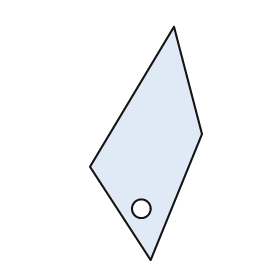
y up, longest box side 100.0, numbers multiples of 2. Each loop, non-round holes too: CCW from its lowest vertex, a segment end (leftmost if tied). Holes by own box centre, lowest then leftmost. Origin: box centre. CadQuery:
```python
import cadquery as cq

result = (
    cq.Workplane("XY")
    .moveTo(2.0, -50.0)
    .lineTo(24.0, 4.0)
    .lineTo(12.0, 50.0)
    .lineTo(-24.0, -10.0)
    .close()
    .moveTo(-2.0, -28.0)
    .circle(4.0)
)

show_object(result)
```